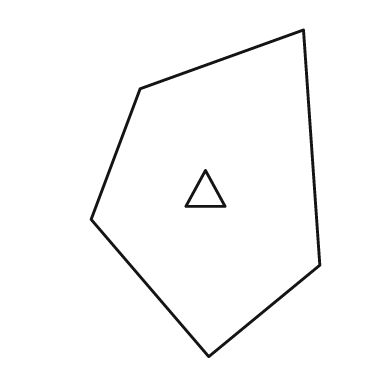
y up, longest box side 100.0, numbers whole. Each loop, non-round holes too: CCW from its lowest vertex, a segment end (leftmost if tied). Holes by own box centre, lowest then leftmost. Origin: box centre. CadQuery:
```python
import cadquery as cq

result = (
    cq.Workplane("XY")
    .moveTo(1.0, -50.0)
    .lineTo(35.0, -22.0)
    .lineTo(30.0, 50.0)
    .lineTo(-20.0, 32.0)
    .lineTo(-35.0, -8.0)
    .close()
    .moveTo(-6.0, -4.0)
    .lineTo(6.0, -4.0)
    .lineTo(0.0, 7.0)
    .close()
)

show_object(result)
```